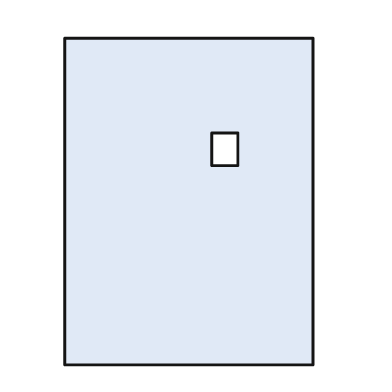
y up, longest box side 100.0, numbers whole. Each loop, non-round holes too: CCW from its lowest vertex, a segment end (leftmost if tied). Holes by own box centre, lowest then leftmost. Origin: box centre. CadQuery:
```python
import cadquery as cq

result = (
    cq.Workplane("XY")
    .moveTo(-38.0, -50.0)
    .lineTo(38.0, -50.0)
    .lineTo(38.0, 50.0)
    .lineTo(-38.0, 50.0)
    .close()
    .moveTo(7.0, 11.0)
    .lineTo(15.0, 11.0)
    .lineTo(15.0, 21.0)
    .lineTo(7.0, 21.0)
    .close()
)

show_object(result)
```